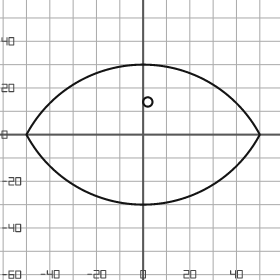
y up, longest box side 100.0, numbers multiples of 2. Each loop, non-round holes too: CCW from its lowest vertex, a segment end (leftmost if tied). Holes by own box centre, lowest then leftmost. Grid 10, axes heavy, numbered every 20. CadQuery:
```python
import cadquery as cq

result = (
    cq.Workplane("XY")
    .moveTo(-50.0, 0.0)
    .threePointArc((0.0, -30.0), (50.0, 0.0))
    .threePointArc((0.0, 30.0), (-50.0, 0.0))
    .close()
    .moveTo(2.0, 14.0)
    .circle(2.0)
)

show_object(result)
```